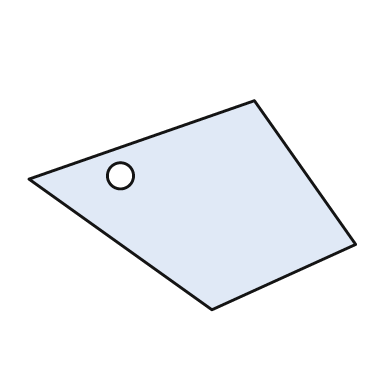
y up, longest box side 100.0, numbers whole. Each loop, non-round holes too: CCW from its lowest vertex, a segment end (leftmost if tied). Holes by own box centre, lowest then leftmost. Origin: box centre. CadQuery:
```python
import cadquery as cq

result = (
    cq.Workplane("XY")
    .moveTo(6.0, -32.0)
    .lineTo(50.0, -12.0)
    .lineTo(19.0, 32.0)
    .lineTo(-50.0, 8.0)
    .close()
    .moveTo(-22.0, 9.0)
    .circle(4.0)
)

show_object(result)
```